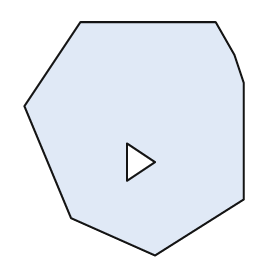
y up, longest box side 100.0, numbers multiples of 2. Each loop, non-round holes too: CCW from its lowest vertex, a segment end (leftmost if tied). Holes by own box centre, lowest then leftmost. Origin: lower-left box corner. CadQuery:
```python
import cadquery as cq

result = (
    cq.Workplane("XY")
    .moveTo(56.0, 0.0)
    .lineTo(94.0, 24.0)
    .lineTo(94.0, 74.0)
    .lineTo(90.0, 86.0)
    .lineTo(82.0, 100.0)
    .lineTo(24.0, 100.0)
    .lineTo(0.0, 64.0)
    .lineTo(20.0, 16.0)
    .close()
    .moveTo(44.0, 32.0)
    .lineTo(56.0, 40.0)
    .lineTo(44.0, 48.0)
    .close()
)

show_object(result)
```